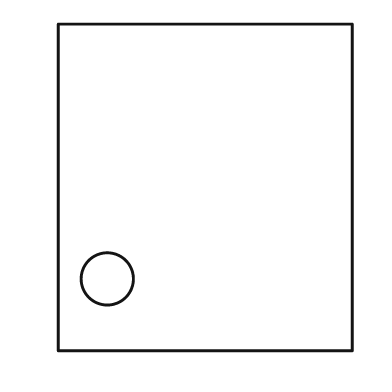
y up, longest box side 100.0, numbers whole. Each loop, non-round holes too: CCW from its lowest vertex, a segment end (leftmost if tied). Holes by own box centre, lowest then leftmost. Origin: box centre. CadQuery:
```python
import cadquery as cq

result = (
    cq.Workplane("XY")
    .moveTo(-45.0, -50.0)
    .lineTo(45.0, -50.0)
    .lineTo(45.0, 50.0)
    .lineTo(-45.0, 50.0)
    .close()
    .moveTo(-30.0, -28.0)
    .circle(8.0)
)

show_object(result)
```